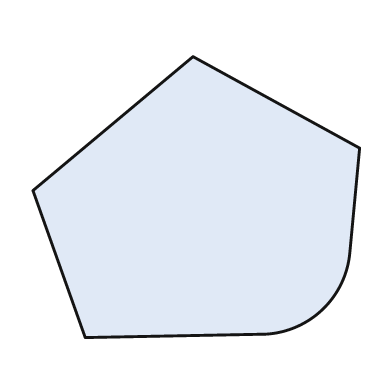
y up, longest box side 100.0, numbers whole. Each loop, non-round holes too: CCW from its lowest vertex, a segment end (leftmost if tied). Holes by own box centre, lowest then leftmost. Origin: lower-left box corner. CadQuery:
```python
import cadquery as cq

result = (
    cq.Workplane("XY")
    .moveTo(16.0, 0.0)
    .lineTo(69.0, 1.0)
    .threePointArc((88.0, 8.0), (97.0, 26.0))
    .lineTo(100.0, 58.0)
    .lineTo(49.0, 86.0)
    .lineTo(0.0, 45.0)
    .close()
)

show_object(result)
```